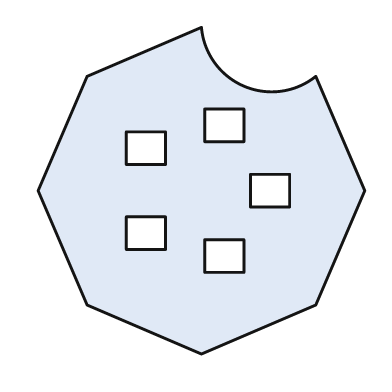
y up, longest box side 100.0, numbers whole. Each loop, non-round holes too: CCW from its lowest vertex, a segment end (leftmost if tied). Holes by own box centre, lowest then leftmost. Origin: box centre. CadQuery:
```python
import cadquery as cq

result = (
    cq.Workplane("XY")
    .moveTo(0.0, -50.0)
    .lineTo(35.0, -35.0)
    .lineTo(50.0, 0.0)
    .lineTo(35.0, 35.0)
    .threePointArc((13.0, 32.0), (0.0, 50.0))
    .lineTo(-35.0, 35.0)
    .lineTo(-50.0, 0.0)
    .lineTo(-35.0, -35.0)
    .close()
    .moveTo(1.0, -25.0)
    .lineTo(13.0, -25.0)
    .lineTo(13.0, -15.0)
    .lineTo(1.0, -15.0)
    .close()
    .moveTo(-23.0, -18.0)
    .lineTo(-11.0, -18.0)
    .lineTo(-11.0, -8.0)
    .lineTo(-23.0, -8.0)
    .close()
    .moveTo(15.0, -5.0)
    .lineTo(27.0, -5.0)
    .lineTo(27.0, 5.0)
    .lineTo(15.0, 5.0)
    .close()
    .moveTo(-23.0, 8.0)
    .lineTo(-11.0, 8.0)
    .lineTo(-11.0, 18.0)
    .lineTo(-23.0, 18.0)
    .close()
    .moveTo(1.0, 15.0)
    .lineTo(13.0, 15.0)
    .lineTo(13.0, 25.0)
    .lineTo(1.0, 25.0)
    .close()
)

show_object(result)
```